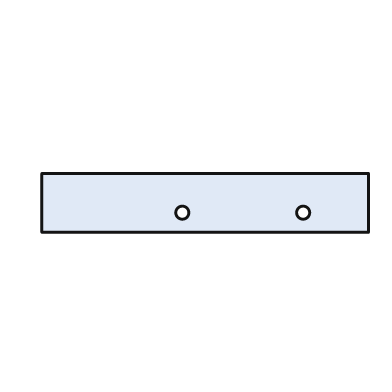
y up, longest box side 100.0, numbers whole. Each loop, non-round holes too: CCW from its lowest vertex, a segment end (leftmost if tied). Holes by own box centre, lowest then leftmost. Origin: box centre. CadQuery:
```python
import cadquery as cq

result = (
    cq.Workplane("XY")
    .moveTo(-50.0, -9.0)
    .lineTo(50.0, -9.0)
    .lineTo(50.0, 9.0)
    .lineTo(-50.0, 9.0)
    .close()
    .moveTo(-7.0, -3.0)
    .circle(2.0)
    .moveTo(30.0, -3.0)
    .circle(2.0)
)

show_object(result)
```